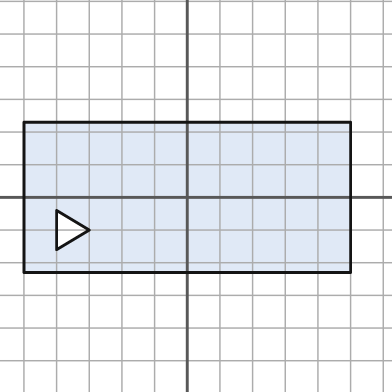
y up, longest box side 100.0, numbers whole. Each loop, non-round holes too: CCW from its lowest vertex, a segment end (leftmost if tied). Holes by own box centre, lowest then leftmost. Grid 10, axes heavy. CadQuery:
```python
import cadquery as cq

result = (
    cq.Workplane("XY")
    .moveTo(-50.0, -23.0)
    .lineTo(50.0, -23.0)
    .lineTo(50.0, 23.0)
    .lineTo(-50.0, 23.0)
    .close()
    .moveTo(-40.0, -16.0)
    .lineTo(-30.0, -10.0)
    .lineTo(-40.0, -4.0)
    .close()
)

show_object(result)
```